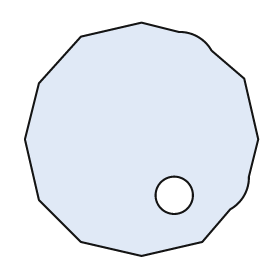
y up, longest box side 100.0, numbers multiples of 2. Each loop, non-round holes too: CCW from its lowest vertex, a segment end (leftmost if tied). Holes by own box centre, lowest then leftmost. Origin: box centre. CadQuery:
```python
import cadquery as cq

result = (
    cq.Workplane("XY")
    .moveTo(0.0, -50.0)
    .lineTo(26.0, -44.0)
    .lineTo(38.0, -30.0)
    .threePointArc((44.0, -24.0), (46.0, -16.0))
    .lineTo(50.0, 0.0)
    .lineTo(44.0, 26.0)
    .lineTo(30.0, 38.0)
    .threePointArc((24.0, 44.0), (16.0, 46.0))
    .lineTo(0.0, 50.0)
    .lineTo(-26.0, 44.0)
    .lineTo(-44.0, 24.0)
    .lineTo(-50.0, 0.0)
    .lineTo(-44.0, -26.0)
    .lineTo(-26.0, -44.0)
    .close()
    .moveTo(14.0, -24.0)
    .circle(8.0)
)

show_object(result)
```